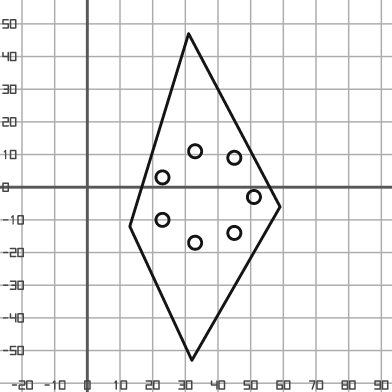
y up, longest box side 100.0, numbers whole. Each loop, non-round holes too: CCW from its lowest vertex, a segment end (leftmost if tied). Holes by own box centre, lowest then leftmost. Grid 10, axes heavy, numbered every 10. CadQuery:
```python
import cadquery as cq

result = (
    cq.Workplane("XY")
    .moveTo(32.0, -53.0)
    .lineTo(59.0, -6.0)
    .lineTo(31.0, 47.0)
    .lineTo(13.0, -12.0)
    .close()
    .moveTo(33.0, -17.0)
    .circle(2.0)
    .moveTo(45.0, -14.0)
    .circle(2.0)
    .moveTo(23.0, -10.0)
    .circle(2.0)
    .moveTo(51.0, -3.0)
    .circle(2.0)
    .moveTo(23.0, 3.0)
    .circle(2.0)
    .moveTo(45.0, 9.0)
    .circle(2.0)
    .moveTo(33.0, 11.0)
    .circle(2.0)
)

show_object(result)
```